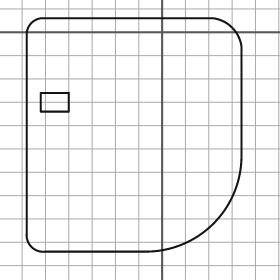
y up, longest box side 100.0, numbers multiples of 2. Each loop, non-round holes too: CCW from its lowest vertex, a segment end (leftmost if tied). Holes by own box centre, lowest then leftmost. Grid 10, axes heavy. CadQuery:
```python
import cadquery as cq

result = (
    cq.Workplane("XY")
    .moveTo(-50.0, -94.0)
    .lineTo(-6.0, -94.0)
    .threePointArc((22.0, -82.0), (34.0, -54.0))
    .lineTo(34.0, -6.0)
    .threePointArc((30.0, 2.0), (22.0, 6.0))
    .lineTo(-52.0, 6.0)
    .threePointArc((-56.0, 4.0), (-58.0, 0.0))
    .lineTo(-58.0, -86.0)
    .threePointArc((-56.0, -92.0), (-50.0, -94.0))
    .close()
    .moveTo(-52.0, -34.0)
    .lineTo(-40.0, -34.0)
    .lineTo(-40.0, -26.0)
    .lineTo(-52.0, -26.0)
    .close()
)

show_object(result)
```